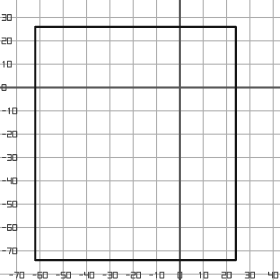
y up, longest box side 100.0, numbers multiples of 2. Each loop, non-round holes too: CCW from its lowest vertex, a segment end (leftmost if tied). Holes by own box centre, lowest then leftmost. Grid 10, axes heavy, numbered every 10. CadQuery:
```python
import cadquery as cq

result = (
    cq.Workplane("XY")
    .moveTo(-62.0, -74.0)
    .lineTo(24.0, -74.0)
    .lineTo(24.0, 26.0)
    .lineTo(-62.0, 26.0)
    .close()
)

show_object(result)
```